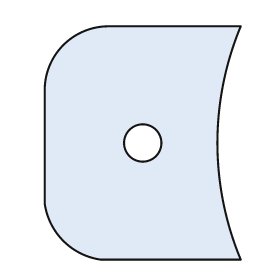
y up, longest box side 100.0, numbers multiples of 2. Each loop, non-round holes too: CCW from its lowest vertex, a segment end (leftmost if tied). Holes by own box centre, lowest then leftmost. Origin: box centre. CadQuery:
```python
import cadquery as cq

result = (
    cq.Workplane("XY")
    .moveTo(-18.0, -50.0)
    .lineTo(42.0, -50.0)
    .threePointArc((32.0, 0.0), (42.0, 50.0))
    .lineTo(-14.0, 50.0)
    .threePointArc((-34.0, 42.0), (-42.0, 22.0))
    .lineTo(-42.0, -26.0)
    .threePointArc((-34.0, -42.0), (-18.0, -50.0))
    .close()
    .moveTo(0.0, 0.0)
    .circle(8.0)
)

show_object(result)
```